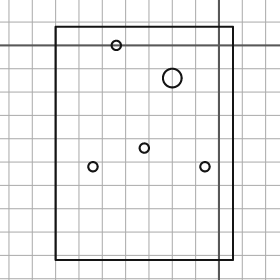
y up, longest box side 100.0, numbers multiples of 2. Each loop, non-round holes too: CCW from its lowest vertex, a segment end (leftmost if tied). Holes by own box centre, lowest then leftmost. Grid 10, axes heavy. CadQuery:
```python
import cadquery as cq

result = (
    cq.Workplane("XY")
    .moveTo(-70.0, -92.0)
    .lineTo(6.0, -92.0)
    .lineTo(6.0, 8.0)
    .lineTo(-70.0, 8.0)
    .close()
    .moveTo(-54.0, -52.0)
    .circle(2.0)
    .moveTo(-6.0, -52.0)
    .circle(2.0)
    .moveTo(-32.0, -44.0)
    .circle(2.0)
    .moveTo(-20.0, -14.0)
    .circle(4.0)
    .moveTo(-44.0, 0.0)
    .circle(2.0)
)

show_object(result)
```